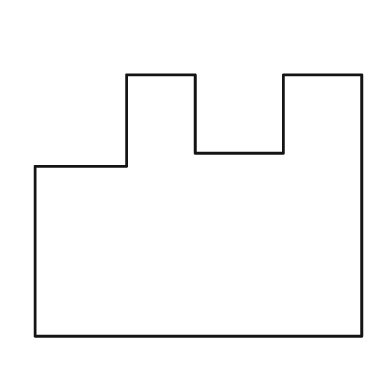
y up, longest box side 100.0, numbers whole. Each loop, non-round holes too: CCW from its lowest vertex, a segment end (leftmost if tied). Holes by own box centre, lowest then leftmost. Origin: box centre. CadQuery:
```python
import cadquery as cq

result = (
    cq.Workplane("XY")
    .moveTo(-50.0, -40.0)
    .lineTo(50.0, -40.0)
    .lineTo(50.0, 40.0)
    .lineTo(26.0, 40.0)
    .lineTo(26.0, 16.0)
    .lineTo(-1.0, 16.0)
    .lineTo(-1.0, 40.0)
    .lineTo(-22.0, 40.0)
    .lineTo(-22.0, 12.0)
    .lineTo(-50.0, 12.0)
    .close()
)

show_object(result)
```